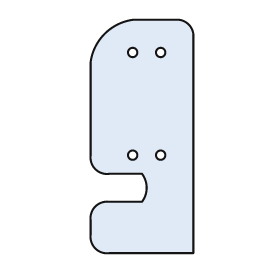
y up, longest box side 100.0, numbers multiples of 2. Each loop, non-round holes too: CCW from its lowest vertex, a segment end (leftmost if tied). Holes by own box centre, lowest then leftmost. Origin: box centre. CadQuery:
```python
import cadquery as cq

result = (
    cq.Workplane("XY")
    .moveTo(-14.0, -50.0)
    .lineTo(22.0, -50.0)
    .lineTo(22.0, 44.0)
    .threePointArc((20.0, 48.0), (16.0, 50.0))
    .lineTo(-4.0, 50.0)
    .threePointArc((-16.0, 44.0), (-22.0, 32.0))
    .lineTo(-22.0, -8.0)
    .threePointArc((-20.0, -14.0), (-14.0, -16.0))
    .lineTo(0.0, -16.0)
    .threePointArc((2.0, -22.0), (0.0, -28.0))
    .lineTo(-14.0, -28.0)
    .threePointArc((-20.0, -30.0), (-22.0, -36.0))
    .lineTo(-22.0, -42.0)
    .threePointArc((-20.0, -48.0), (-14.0, -50.0))
    .close()
    .moveTo(-4.0, -8.0)
    .circle(2.0)
    .moveTo(8.0, -8.0)
    .circle(2.0)
    .moveTo(-4.0, 36.0)
    .circle(2.0)
    .moveTo(8.0, 36.0)
    .circle(2.0)
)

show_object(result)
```